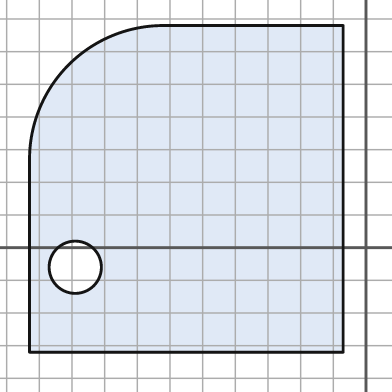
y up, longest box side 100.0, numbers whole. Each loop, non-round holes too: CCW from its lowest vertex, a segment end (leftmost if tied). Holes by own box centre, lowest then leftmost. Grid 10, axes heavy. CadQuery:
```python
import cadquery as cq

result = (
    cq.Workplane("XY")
    .moveTo(-103.0, -32.0)
    .lineTo(-7.0, -32.0)
    .lineTo(-7.0, 68.0)
    .lineTo(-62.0, 68.0)
    .threePointArc((-91.0, 56.0), (-103.0, 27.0))
    .close()
    .moveTo(-89.0, -6.0)
    .circle(8.0)
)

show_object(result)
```